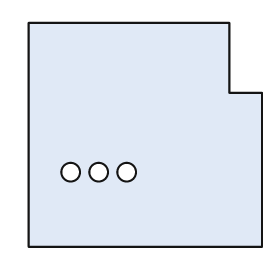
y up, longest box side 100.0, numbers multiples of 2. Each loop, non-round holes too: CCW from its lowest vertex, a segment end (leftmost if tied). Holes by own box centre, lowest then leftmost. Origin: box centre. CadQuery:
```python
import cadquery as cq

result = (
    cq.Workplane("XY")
    .moveTo(-50.0, -48.0)
    .lineTo(50.0, -48.0)
    .lineTo(50.0, 18.0)
    .lineTo(36.0, 18.0)
    .lineTo(36.0, 48.0)
    .lineTo(-50.0, 48.0)
    .close()
    .moveTo(-32.0, -16.0)
    .circle(4.0)
    .moveTo(-20.0, -16.0)
    .circle(4.0)
    .moveTo(-8.0, -16.0)
    .circle(4.0)
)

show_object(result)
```